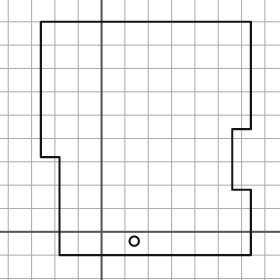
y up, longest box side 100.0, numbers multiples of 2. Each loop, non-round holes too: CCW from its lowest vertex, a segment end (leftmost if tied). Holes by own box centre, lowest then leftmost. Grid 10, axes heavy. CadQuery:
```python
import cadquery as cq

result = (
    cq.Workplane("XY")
    .moveTo(-18.0, -10.0)
    .lineTo(64.0, -10.0)
    .lineTo(64.0, 18.0)
    .lineTo(56.0, 18.0)
    .lineTo(56.0, 44.0)
    .lineTo(64.0, 44.0)
    .lineTo(64.0, 90.0)
    .lineTo(-26.0, 90.0)
    .lineTo(-26.0, 32.0)
    .lineTo(-18.0, 32.0)
    .close()
    .moveTo(14.0, -4.0)
    .circle(2.0)
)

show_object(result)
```